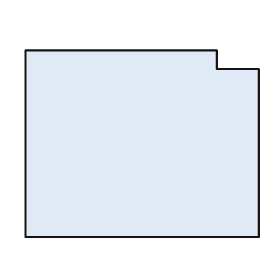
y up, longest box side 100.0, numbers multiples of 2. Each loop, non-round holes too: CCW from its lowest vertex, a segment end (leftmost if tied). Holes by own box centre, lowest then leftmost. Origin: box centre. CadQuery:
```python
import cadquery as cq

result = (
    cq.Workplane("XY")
    .moveTo(-50.0, -40.0)
    .lineTo(50.0, -40.0)
    .lineTo(50.0, 32.0)
    .lineTo(32.0, 32.0)
    .lineTo(32.0, 40.0)
    .lineTo(-50.0, 40.0)
    .close()
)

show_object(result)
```